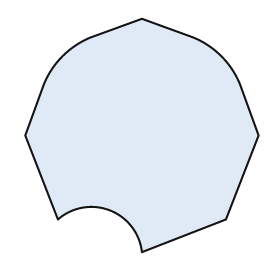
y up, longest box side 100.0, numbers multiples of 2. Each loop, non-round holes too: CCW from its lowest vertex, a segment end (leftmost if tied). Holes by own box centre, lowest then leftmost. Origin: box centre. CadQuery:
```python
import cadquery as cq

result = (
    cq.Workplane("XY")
    .moveTo(0.0, -50.0)
    .lineTo(36.0, -36.0)
    .lineTo(50.0, 0.0)
    .lineTo(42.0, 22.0)
    .threePointArc((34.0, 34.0), (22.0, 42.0))
    .lineTo(0.0, 50.0)
    .lineTo(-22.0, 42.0)
    .threePointArc((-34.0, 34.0), (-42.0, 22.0))
    .lineTo(-50.0, 0.0)
    .lineTo(-36.0, -36.0)
    .threePointArc((-14.0, -32.0), (0.0, -50.0))
    .close()
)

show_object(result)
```